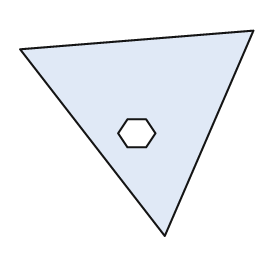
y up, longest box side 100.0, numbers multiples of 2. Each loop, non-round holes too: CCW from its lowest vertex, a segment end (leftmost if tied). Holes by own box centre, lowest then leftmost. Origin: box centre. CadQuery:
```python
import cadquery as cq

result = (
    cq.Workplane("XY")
    .moveTo(12.0, -44.0)
    .lineTo(50.0, 44.0)
    .lineTo(-50.0, 36.0)
    .close()
    .moveTo(-4.0, -6.0)
    .lineTo(4.0, -6.0)
    .lineTo(8.0, 0.0)
    .lineTo(4.0, 6.0)
    .lineTo(-4.0, 6.0)
    .lineTo(-8.0, 0.0)
    .close()
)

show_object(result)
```